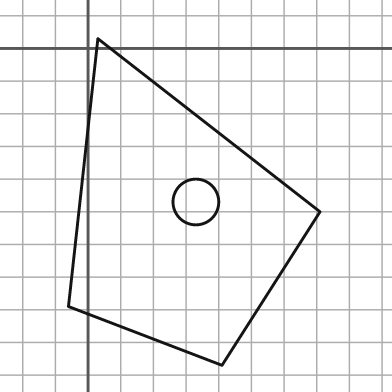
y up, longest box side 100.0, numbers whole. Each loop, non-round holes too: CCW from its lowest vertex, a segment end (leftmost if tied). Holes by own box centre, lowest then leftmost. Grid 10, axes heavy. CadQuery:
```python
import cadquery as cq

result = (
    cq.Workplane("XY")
    .moveTo(41.0, -97.0)
    .lineTo(71.0, -50.0)
    .lineTo(3.0, 3.0)
    .lineTo(-6.0, -79.0)
    .close()
    .moveTo(33.0, -47.0)
    .circle(7.0)
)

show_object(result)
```